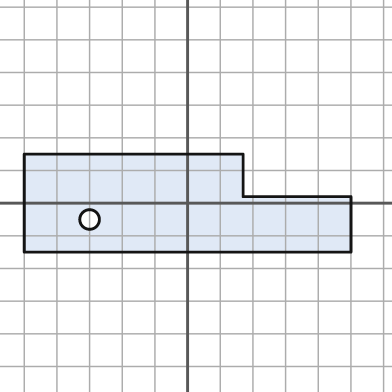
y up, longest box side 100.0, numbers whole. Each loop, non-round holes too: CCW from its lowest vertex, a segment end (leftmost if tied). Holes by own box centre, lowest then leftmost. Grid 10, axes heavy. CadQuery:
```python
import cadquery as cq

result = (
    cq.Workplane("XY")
    .moveTo(-50.0, -15.0)
    .lineTo(50.0, -15.0)
    .lineTo(50.0, 2.0)
    .lineTo(17.0, 2.0)
    .lineTo(17.0, 15.0)
    .lineTo(-50.0, 15.0)
    .close()
    .moveTo(-30.0, -5.0)
    .circle(3.0)
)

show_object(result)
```